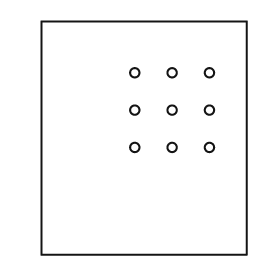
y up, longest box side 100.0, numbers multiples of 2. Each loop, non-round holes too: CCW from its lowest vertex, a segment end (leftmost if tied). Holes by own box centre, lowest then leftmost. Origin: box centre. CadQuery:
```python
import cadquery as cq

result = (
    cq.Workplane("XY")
    .moveTo(-44.0, -50.0)
    .lineTo(44.0, -50.0)
    .lineTo(44.0, 50.0)
    .lineTo(-44.0, 50.0)
    .close()
    .moveTo(-4.0, -4.0)
    .circle(2.0)
    .moveTo(12.0, -4.0)
    .circle(2.0)
    .moveTo(28.0, -4.0)
    .circle(2.0)
    .moveTo(-4.0, 12.0)
    .circle(2.0)
    .moveTo(12.0, 12.0)
    .circle(2.0)
    .moveTo(28.0, 12.0)
    .circle(2.0)
    .moveTo(-4.0, 28.0)
    .circle(2.0)
    .moveTo(12.0, 28.0)
    .circle(2.0)
    .moveTo(28.0, 28.0)
    .circle(2.0)
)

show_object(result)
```